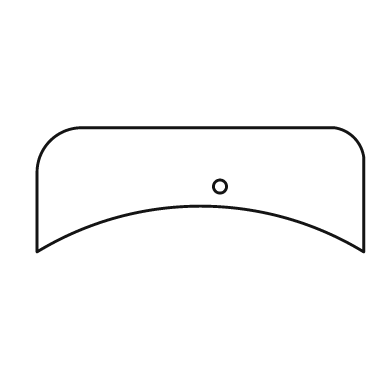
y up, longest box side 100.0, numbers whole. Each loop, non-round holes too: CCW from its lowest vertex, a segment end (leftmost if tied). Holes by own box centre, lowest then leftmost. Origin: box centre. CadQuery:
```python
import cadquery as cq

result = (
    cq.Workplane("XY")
    .moveTo(-50.0, -19.0)
    .threePointArc((0.0, -5.0), (50.0, -19.0))
    .lineTo(50.0, 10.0)
    .threePointArc((47.0, 16.0), (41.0, 19.0))
    .lineTo(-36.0, 19.0)
    .threePointArc((-46.0, 15.0), (-50.0, 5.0))
    .close()
    .moveTo(6.0, 1.0)
    .circle(2.0)
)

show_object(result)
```